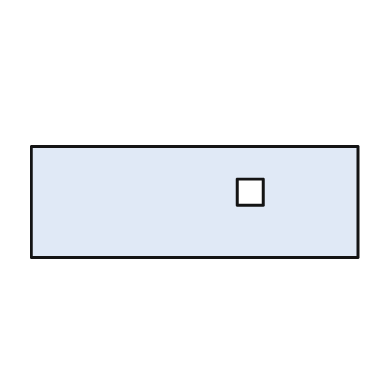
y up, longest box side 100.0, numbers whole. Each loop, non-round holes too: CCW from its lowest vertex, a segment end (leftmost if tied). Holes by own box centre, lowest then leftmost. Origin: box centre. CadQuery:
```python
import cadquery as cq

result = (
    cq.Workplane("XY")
    .moveTo(-50.0, -17.0)
    .lineTo(50.0, -17.0)
    .lineTo(50.0, 17.0)
    .lineTo(-50.0, 17.0)
    .close()
    .moveTo(13.0, -1.0)
    .lineTo(21.0, -1.0)
    .lineTo(21.0, 7.0)
    .lineTo(13.0, 7.0)
    .close()
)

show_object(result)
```